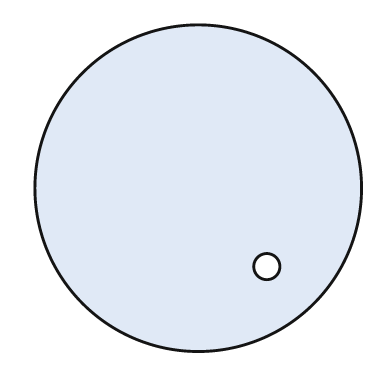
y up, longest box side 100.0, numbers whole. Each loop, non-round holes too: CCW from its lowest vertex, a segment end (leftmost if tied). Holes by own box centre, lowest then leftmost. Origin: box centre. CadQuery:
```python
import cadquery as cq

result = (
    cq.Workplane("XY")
    .moveTo(0.0, 0.0)
    .circle(50.0)
    .moveTo(21.0, -24.0)
    .circle(4.0)
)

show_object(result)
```